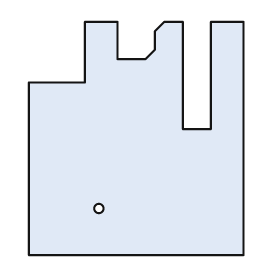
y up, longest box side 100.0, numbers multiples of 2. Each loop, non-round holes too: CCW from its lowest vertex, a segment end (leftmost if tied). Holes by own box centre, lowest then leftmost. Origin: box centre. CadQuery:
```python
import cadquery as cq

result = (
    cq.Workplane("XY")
    .moveTo(-46.0, -50.0)
    .lineTo(46.0, -50.0)
    .lineTo(46.0, 50.0)
    .lineTo(32.0, 50.0)
    .lineTo(32.0, 4.0)
    .lineTo(20.0, 4.0)
    .lineTo(20.0, 50.0)
    .lineTo(12.0, 50.0)
    .lineTo(8.0, 46.0)
    .lineTo(8.0, 38.0)
    .lineTo(4.0, 34.0)
    .lineTo(-8.0, 34.0)
    .lineTo(-8.0, 50.0)
    .lineTo(-22.0, 50.0)
    .lineTo(-22.0, 24.0)
    .lineTo(-46.0, 24.0)
    .close()
    .moveTo(-16.0, -30.0)
    .circle(2.0)
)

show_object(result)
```